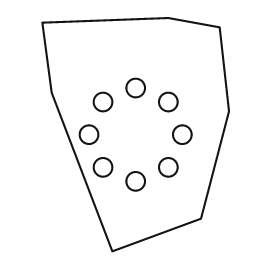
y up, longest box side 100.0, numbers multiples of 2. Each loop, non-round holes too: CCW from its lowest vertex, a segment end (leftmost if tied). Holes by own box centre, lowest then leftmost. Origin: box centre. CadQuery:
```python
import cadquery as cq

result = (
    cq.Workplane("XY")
    .moveTo(-10.0, -50.0)
    .lineTo(28.0, -36.0)
    .lineTo(40.0, 10.0)
    .lineTo(36.0, 46.0)
    .lineTo(14.0, 50.0)
    .lineTo(-40.0, 48.0)
    .lineTo(-36.0, 18.0)
    .close()
    .moveTo(0.0, -20.0)
    .circle(4.0)
    .moveTo(-14.0, -14.0)
    .circle(4.0)
    .moveTo(14.0, -14.0)
    .circle(4.0)
    .moveTo(-20.0, 0.0)
    .circle(4.0)
    .moveTo(20.0, 0.0)
    .circle(4.0)
    .moveTo(-14.0, 14.0)
    .circle(4.0)
    .moveTo(14.0, 14.0)
    .circle(4.0)
    .moveTo(0.0, 20.0)
    .circle(4.0)
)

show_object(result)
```